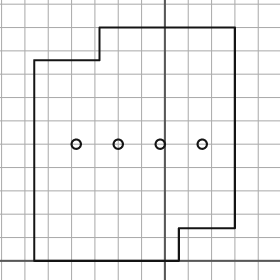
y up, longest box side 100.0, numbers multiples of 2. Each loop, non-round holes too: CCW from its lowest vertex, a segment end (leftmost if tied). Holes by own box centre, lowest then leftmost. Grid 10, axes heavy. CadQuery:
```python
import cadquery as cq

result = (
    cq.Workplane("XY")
    .moveTo(-56.0, 0.0)
    .lineTo(6.0, 0.0)
    .lineTo(6.0, 14.0)
    .lineTo(30.0, 14.0)
    .lineTo(30.0, 100.0)
    .lineTo(-28.0, 100.0)
    .lineTo(-28.0, 86.0)
    .lineTo(-56.0, 86.0)
    .close()
    .moveTo(-38.0, 50.0)
    .circle(2.0)
    .moveTo(-20.0, 50.0)
    .circle(2.0)
    .moveTo(-2.0, 50.0)
    .circle(2.0)
    .moveTo(16.0, 50.0)
    .circle(2.0)
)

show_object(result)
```